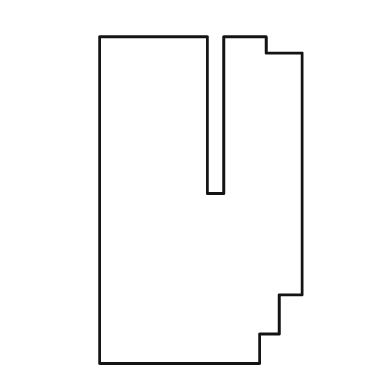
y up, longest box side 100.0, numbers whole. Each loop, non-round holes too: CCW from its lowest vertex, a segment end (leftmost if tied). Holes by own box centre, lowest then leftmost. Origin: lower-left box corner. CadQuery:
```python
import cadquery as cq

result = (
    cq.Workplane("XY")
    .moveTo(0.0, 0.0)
    .lineTo(49.0, 0.0)
    .lineTo(49.0, 9.0)
    .lineTo(55.0, 9.0)
    .lineTo(55.0, 21.0)
    .lineTo(62.0, 21.0)
    .lineTo(62.0, 95.0)
    .lineTo(51.0, 95.0)
    .lineTo(51.0, 100.0)
    .lineTo(38.0, 100.0)
    .lineTo(38.0, 52.0)
    .lineTo(33.0, 52.0)
    .lineTo(33.0, 100.0)
    .lineTo(0.0, 100.0)
    .close()
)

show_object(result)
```